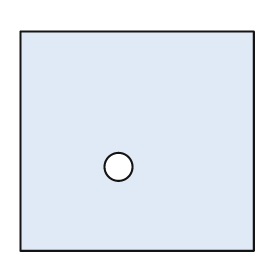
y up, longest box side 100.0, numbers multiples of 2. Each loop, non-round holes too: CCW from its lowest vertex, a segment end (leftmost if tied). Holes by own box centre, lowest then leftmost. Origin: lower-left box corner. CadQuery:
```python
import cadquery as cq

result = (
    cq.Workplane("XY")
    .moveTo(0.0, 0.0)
    .lineTo(100.0, 0.0)
    .lineTo(100.0, 94.0)
    .lineTo(0.0, 94.0)
    .close()
    .moveTo(42.0, 36.0)
    .circle(6.0)
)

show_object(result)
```